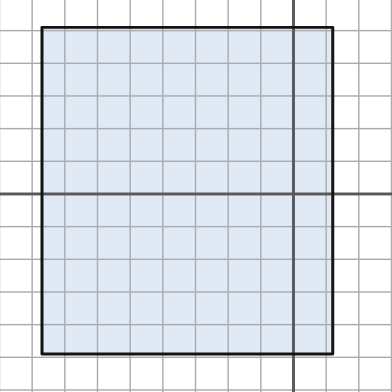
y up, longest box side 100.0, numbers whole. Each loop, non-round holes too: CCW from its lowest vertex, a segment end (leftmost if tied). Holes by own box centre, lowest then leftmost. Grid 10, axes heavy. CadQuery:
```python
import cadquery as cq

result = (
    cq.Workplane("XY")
    .moveTo(-77.0, -49.0)
    .lineTo(12.0, -49.0)
    .lineTo(12.0, 51.0)
    .lineTo(-77.0, 51.0)
    .close()
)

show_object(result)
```